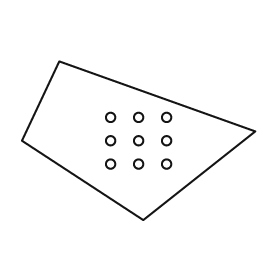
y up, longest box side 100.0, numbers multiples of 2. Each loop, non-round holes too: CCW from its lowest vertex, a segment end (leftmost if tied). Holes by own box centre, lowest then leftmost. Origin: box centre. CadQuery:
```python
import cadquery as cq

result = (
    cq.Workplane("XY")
    .moveTo(2.0, -34.0)
    .lineTo(50.0, 4.0)
    .lineTo(-34.0, 34.0)
    .lineTo(-50.0, 0.0)
    .close()
    .moveTo(-12.0, -10.0)
    .circle(2.0)
    .moveTo(0.0, -10.0)
    .circle(2.0)
    .moveTo(12.0, -10.0)
    .circle(2.0)
    .moveTo(-12.0, 0.0)
    .circle(2.0)
    .moveTo(0.0, 0.0)
    .circle(2.0)
    .moveTo(12.0, 0.0)
    .circle(2.0)
    .moveTo(-12.0, 10.0)
    .circle(2.0)
    .moveTo(0.0, 10.0)
    .circle(2.0)
    .moveTo(12.0, 10.0)
    .circle(2.0)
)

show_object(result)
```